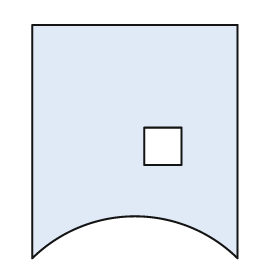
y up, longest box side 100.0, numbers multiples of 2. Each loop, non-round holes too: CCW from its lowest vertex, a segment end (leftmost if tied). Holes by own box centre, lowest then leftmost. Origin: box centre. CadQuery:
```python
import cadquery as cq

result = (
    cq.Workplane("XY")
    .moveTo(-44.0, -50.0)
    .threePointArc((0.0, -32.0), (44.0, -50.0))
    .lineTo(44.0, 50.0)
    .lineTo(-44.0, 50.0)
    .close()
    .moveTo(4.0, -10.0)
    .lineTo(20.0, -10.0)
    .lineTo(20.0, 6.0)
    .lineTo(4.0, 6.0)
    .close()
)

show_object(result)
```